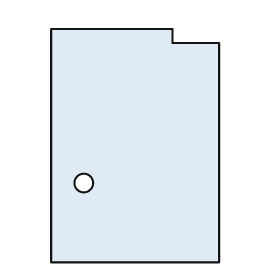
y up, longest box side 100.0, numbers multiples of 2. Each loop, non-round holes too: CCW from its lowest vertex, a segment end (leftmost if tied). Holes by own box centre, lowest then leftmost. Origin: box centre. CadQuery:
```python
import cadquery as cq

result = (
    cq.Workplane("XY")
    .moveTo(-36.0, -50.0)
    .lineTo(36.0, -50.0)
    .lineTo(36.0, 44.0)
    .lineTo(16.0, 44.0)
    .lineTo(16.0, 50.0)
    .lineTo(-36.0, 50.0)
    .close()
    .moveTo(-22.0, -16.0)
    .circle(4.0)
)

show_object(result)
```